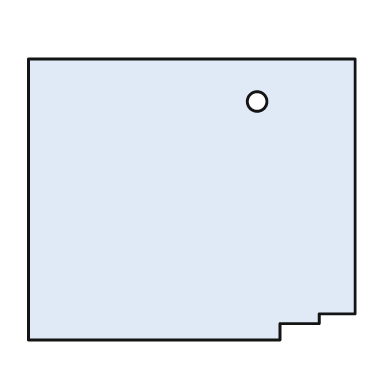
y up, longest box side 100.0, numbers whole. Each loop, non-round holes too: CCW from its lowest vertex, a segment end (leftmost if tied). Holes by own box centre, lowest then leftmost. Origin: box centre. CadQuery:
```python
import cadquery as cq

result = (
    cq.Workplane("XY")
    .moveTo(-50.0, -43.0)
    .lineTo(27.0, -43.0)
    .lineTo(27.0, -38.0)
    .lineTo(39.0, -38.0)
    .lineTo(39.0, -35.0)
    .lineTo(50.0, -35.0)
    .lineTo(50.0, 43.0)
    .lineTo(-50.0, 43.0)
    .close()
    .moveTo(20.0, 30.0)
    .circle(3.0)
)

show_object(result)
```